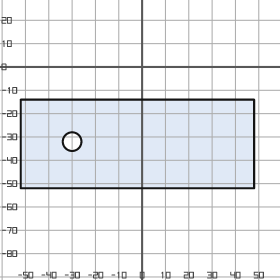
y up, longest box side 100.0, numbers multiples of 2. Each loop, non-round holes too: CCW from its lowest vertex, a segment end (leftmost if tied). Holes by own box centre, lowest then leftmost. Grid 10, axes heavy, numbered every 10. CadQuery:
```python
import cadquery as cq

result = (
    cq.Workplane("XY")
    .moveTo(-52.0, -52.0)
    .lineTo(48.0, -52.0)
    .lineTo(48.0, -14.0)
    .lineTo(-52.0, -14.0)
    .close()
    .moveTo(-30.0, -32.0)
    .circle(4.0)
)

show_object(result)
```